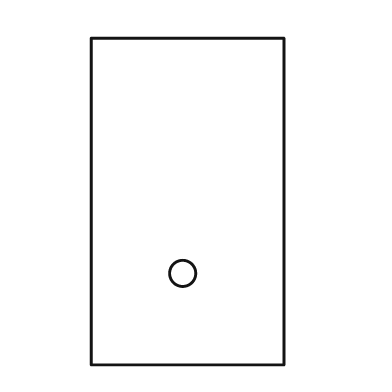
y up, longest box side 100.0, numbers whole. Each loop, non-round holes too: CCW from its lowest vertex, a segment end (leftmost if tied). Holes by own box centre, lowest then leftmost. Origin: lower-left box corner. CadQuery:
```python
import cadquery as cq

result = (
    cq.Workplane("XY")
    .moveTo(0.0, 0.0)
    .lineTo(59.0, 0.0)
    .lineTo(59.0, 100.0)
    .lineTo(0.0, 100.0)
    .close()
    .moveTo(28.0, 28.0)
    .circle(4.0)
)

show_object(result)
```